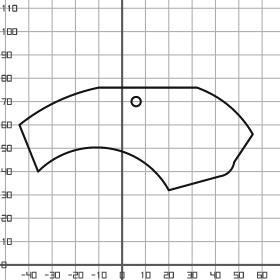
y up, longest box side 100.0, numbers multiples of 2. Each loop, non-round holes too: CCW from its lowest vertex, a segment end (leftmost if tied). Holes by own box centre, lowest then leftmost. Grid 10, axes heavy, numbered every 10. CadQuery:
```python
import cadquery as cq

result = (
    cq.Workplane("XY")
    .moveTo(20.0, 32.0)
    .lineTo(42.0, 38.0)
    .threePointArc((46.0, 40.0), (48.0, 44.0))
    .lineTo(56.0, 56.0)
    .threePointArc((46.0, 68.0), (32.0, 76.0))
    .lineTo(-10.0, 76.0)
    .threePointArc((-28.0, 70.0), (-44.0, 60.0))
    .lineTo(-36.0, 40.0)
    .threePointArc((-6.0, 50.0), (20.0, 32.0))
    .close()
    .moveTo(6.0, 70.0)
    .circle(2.0)
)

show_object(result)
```